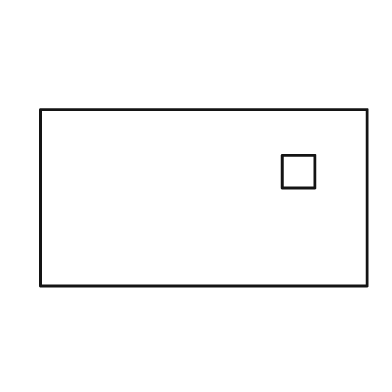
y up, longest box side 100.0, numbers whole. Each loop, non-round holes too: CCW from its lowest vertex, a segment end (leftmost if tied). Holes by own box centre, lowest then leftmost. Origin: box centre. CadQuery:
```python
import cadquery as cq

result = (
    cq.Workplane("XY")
    .moveTo(-50.0, -27.0)
    .lineTo(50.0, -27.0)
    .lineTo(50.0, 27.0)
    .lineTo(-50.0, 27.0)
    .close()
    .moveTo(24.0, 3.0)
    .lineTo(34.0, 3.0)
    .lineTo(34.0, 13.0)
    .lineTo(24.0, 13.0)
    .close()
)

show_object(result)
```